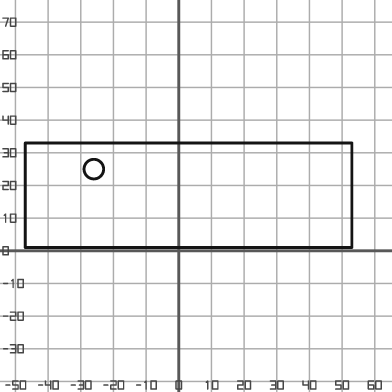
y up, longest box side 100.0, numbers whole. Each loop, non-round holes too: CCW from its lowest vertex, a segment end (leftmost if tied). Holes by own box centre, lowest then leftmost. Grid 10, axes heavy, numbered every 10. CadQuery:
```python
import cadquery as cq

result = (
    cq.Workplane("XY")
    .moveTo(-47.0, 1.0)
    .lineTo(53.0, 1.0)
    .lineTo(53.0, 33.0)
    .lineTo(-47.0, 33.0)
    .close()
    .moveTo(-26.0, 25.0)
    .circle(3.0)
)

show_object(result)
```